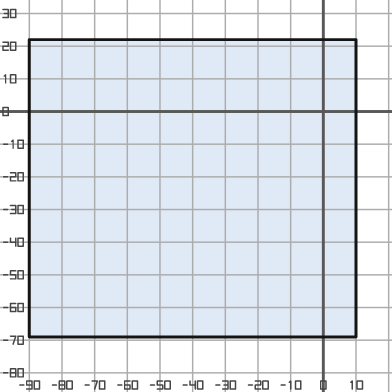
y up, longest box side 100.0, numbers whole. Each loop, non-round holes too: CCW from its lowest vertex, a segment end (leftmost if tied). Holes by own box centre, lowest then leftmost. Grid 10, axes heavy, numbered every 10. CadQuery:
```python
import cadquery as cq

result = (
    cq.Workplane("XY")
    .moveTo(-90.0, -69.0)
    .lineTo(10.0, -69.0)
    .lineTo(10.0, 22.0)
    .lineTo(-90.0, 22.0)
    .close()
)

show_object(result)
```